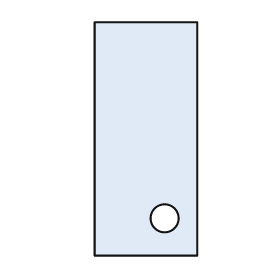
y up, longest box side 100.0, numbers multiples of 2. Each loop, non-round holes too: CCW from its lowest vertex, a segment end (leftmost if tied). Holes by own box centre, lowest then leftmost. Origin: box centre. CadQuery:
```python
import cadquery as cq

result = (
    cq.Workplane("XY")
    .moveTo(-22.0, -50.0)
    .lineTo(22.0, -50.0)
    .lineTo(22.0, 50.0)
    .lineTo(-22.0, 50.0)
    .close()
    .moveTo(8.0, -34.0)
    .circle(6.0)
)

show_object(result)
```